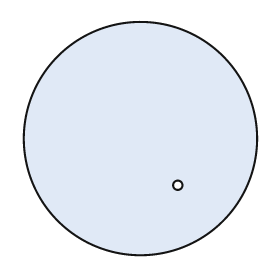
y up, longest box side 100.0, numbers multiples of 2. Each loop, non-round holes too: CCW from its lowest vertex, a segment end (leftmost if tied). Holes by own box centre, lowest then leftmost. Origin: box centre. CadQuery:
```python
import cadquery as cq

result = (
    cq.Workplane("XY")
    .moveTo(0.0, 0.0)
    .circle(50.0)
    .moveTo(16.0, -20.0)
    .circle(2.0)
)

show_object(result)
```